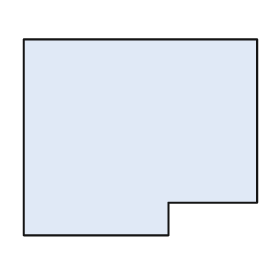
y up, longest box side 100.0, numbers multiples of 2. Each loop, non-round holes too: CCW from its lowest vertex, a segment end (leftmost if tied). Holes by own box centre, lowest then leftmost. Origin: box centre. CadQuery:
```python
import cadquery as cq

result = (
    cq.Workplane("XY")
    .moveTo(-50.0, -42.0)
    .lineTo(12.0, -42.0)
    .lineTo(12.0, -28.0)
    .lineTo(50.0, -28.0)
    .lineTo(50.0, 42.0)
    .lineTo(-50.0, 42.0)
    .close()
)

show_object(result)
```